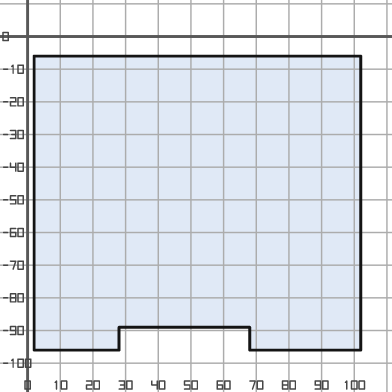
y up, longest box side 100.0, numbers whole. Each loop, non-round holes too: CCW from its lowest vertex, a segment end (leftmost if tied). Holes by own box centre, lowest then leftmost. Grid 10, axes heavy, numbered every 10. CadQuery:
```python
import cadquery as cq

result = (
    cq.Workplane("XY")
    .moveTo(2.0, -96.0)
    .lineTo(28.0, -96.0)
    .lineTo(28.0, -89.0)
    .lineTo(68.0, -89.0)
    .lineTo(68.0, -96.0)
    .lineTo(102.0, -96.0)
    .lineTo(102.0, -6.0)
    .lineTo(2.0, -6.0)
    .close()
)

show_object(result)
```